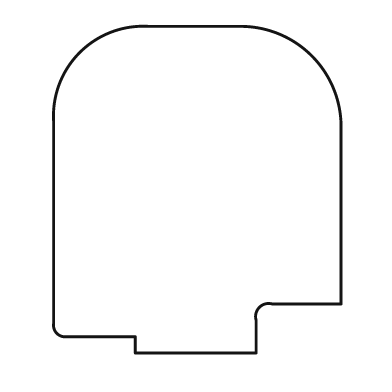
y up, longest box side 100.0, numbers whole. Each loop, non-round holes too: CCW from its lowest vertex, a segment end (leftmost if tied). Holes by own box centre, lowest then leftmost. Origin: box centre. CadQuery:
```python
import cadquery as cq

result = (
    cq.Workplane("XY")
    .moveTo(-19.0, -50.0)
    .lineTo(18.0, -50.0)
    .lineTo(18.0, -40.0)
    .threePointArc((19.0, -36.0), (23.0, -35.0))
    .lineTo(44.0, -35.0)
    .lineTo(44.0, 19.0)
    .threePointArc((35.0, 41.0), (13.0, 50.0))
    .lineTo(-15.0, 50.0)
    .threePointArc((-36.0, 42.0), (-44.0, 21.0))
    .lineTo(-44.0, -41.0)
    .threePointArc((-43.0, -44.0), (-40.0, -45.0))
    .lineTo(-19.0, -45.0)
    .close()
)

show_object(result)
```